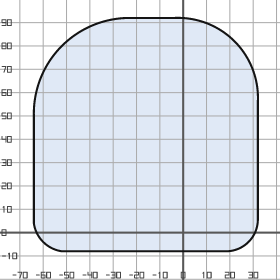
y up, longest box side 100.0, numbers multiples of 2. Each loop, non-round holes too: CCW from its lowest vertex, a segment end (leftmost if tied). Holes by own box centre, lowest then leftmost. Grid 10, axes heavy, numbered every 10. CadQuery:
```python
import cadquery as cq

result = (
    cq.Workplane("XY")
    .moveTo(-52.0, -8.0)
    .lineTo(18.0, -8.0)
    .threePointArc((28.0, -4.0), (32.0, 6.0))
    .lineTo(32.0, 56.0)
    .threePointArc((22.0, 82.0), (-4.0, 92.0))
    .lineTo(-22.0, 92.0)
    .threePointArc((-52.0, 80.0), (-64.0, 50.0))
    .lineTo(-64.0, 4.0)
    .threePointArc((-60.0, -4.0), (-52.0, -8.0))
    .close()
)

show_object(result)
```